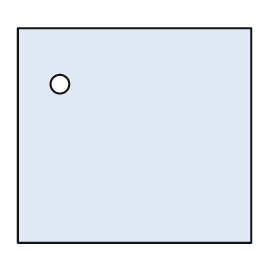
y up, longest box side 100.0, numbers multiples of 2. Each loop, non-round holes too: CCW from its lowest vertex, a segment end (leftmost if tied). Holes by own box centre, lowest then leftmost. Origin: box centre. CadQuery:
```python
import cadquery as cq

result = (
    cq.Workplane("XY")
    .moveTo(-50.0, -46.0)
    .lineTo(50.0, -46.0)
    .lineTo(50.0, 46.0)
    .lineTo(-50.0, 46.0)
    .close()
    .moveTo(-32.0, 22.0)
    .circle(4.0)
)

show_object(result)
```